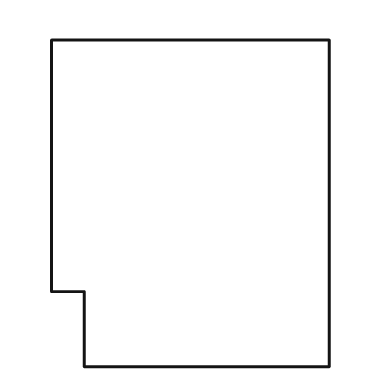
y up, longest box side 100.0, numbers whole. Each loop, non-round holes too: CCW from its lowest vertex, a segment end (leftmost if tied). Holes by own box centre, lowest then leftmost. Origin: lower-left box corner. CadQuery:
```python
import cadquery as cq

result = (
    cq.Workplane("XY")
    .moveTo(10.0, 0.0)
    .lineTo(85.0, 0.0)
    .lineTo(85.0, 100.0)
    .lineTo(0.0, 100.0)
    .lineTo(0.0, 23.0)
    .lineTo(10.0, 23.0)
    .close()
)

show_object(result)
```